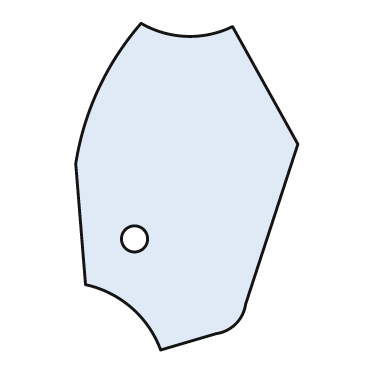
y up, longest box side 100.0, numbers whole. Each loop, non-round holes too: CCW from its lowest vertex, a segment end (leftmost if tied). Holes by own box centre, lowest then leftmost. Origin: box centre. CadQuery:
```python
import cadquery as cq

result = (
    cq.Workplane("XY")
    .moveTo(-8.0, -50.0)
    .lineTo(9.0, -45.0)
    .threePointArc((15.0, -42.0), (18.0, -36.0))
    .lineTo(34.0, 13.0)
    .lineTo(14.0, 49.0)
    .threePointArc((0.0, 46.0), (-14.0, 50.0))
    .threePointArc((-27.0, 30.0), (-34.0, 7.0))
    .lineTo(-31.0, -30.0)
    .threePointArc((-17.0, -37.0), (-8.0, -50.0))
    .close()
    .moveTo(-16.0, -16.0)
    .circle(4.0)
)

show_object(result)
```